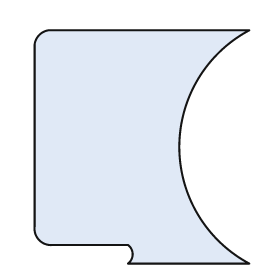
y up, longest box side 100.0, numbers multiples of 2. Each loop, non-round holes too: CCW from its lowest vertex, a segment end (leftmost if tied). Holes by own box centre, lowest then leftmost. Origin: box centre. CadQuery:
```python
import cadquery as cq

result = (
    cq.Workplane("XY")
    .moveTo(-6.0, -50.0)
    .lineTo(46.0, -50.0)
    .threePointArc((16.0, 0.0), (46.0, 50.0))
    .lineTo(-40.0, 50.0)
    .threePointArc((-44.0, 48.0), (-46.0, 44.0))
    .lineTo(-46.0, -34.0)
    .threePointArc((-44.0, -40.0), (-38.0, -42.0))
    .lineTo(-6.0, -42.0)
    .threePointArc((-4.0, -46.0), (-6.0, -50.0))
    .close()
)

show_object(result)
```